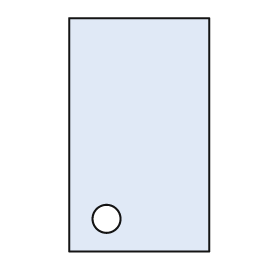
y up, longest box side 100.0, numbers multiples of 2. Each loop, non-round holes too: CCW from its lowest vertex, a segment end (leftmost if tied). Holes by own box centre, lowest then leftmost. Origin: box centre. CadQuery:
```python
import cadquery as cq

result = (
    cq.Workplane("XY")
    .moveTo(-30.0, -50.0)
    .lineTo(30.0, -50.0)
    .lineTo(30.0, 50.0)
    .lineTo(-30.0, 50.0)
    .close()
    .moveTo(-14.0, -36.0)
    .circle(6.0)
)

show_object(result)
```